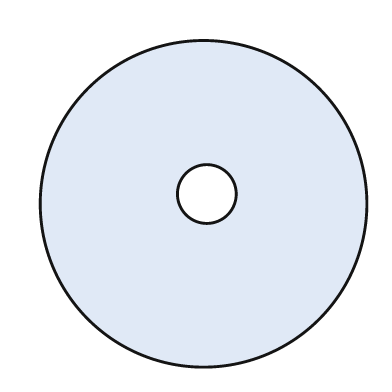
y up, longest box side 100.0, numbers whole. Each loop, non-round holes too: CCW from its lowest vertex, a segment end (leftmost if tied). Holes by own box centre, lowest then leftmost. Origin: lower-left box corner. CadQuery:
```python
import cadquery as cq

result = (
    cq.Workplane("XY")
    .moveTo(50.0, 50.0)
    .circle(50.0)
    .moveTo(51.0, 53.0)
    .circle(9.0)
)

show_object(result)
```